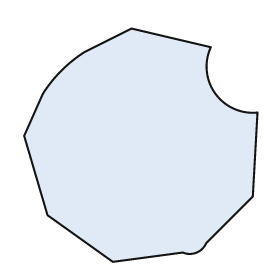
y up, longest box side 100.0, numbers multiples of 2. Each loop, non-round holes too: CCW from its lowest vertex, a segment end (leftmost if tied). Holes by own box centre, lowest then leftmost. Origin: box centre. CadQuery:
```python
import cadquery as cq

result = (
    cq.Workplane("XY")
    .moveTo(-12.0, -50.0)
    .lineTo(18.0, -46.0)
    .threePointArc((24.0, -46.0), (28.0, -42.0))
    .lineTo(48.0, -22.0)
    .lineTo(50.0, 14.0)
    .threePointArc((32.0, 22.0), (30.0, 42.0))
    .lineTo(-4.0, 50.0)
    .lineTo(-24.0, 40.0)
    .threePointArc((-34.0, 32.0), (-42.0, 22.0))
    .lineTo(-50.0, 4.0)
    .lineTo(-40.0, -30.0)
    .close()
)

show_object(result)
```